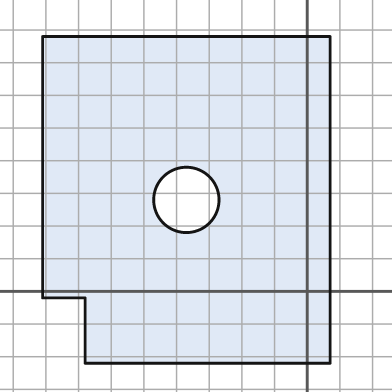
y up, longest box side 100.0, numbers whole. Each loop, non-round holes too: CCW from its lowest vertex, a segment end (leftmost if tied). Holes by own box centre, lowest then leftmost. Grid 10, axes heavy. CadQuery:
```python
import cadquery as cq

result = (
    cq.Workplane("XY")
    .moveTo(-68.0, -22.0)
    .lineTo(7.0, -22.0)
    .lineTo(7.0, 78.0)
    .lineTo(-81.0, 78.0)
    .lineTo(-81.0, -2.0)
    .lineTo(-68.0, -2.0)
    .close()
    .moveTo(-37.0, 28.0)
    .circle(10.0)
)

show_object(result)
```